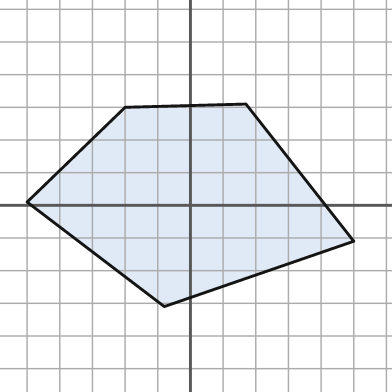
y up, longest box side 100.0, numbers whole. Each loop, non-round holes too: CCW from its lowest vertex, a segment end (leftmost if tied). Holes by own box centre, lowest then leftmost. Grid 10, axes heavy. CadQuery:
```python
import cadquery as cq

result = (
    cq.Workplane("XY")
    .moveTo(-8.0, -31.0)
    .lineTo(50.0, -11.0)
    .lineTo(17.0, 31.0)
    .lineTo(-20.0, 30.0)
    .lineTo(-50.0, 1.0)
    .close()
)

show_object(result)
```